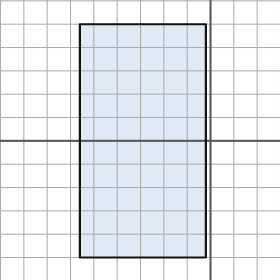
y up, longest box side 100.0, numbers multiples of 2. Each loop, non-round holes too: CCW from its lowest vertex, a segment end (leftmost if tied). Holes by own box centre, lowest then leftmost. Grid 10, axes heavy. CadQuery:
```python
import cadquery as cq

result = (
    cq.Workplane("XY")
    .moveTo(-56.0, -50.0)
    .lineTo(-2.0, -50.0)
    .lineTo(-2.0, 50.0)
    .lineTo(-56.0, 50.0)
    .close()
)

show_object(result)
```